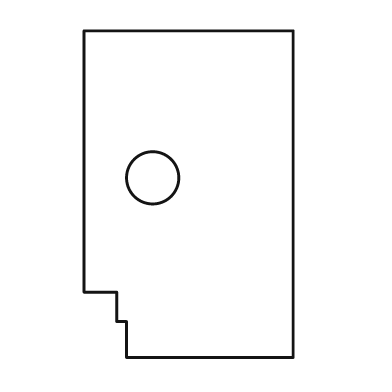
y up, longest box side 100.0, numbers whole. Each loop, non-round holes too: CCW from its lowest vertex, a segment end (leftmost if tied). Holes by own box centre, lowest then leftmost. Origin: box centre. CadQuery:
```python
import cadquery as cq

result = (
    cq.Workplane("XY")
    .moveTo(-19.0, -50.0)
    .lineTo(32.0, -50.0)
    .lineTo(32.0, 50.0)
    .lineTo(-32.0, 50.0)
    .lineTo(-32.0, -30.0)
    .lineTo(-22.0, -30.0)
    .lineTo(-22.0, -39.0)
    .lineTo(-19.0, -39.0)
    .close()
    .moveTo(-11.0, 5.0)
    .circle(8.0)
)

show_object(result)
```